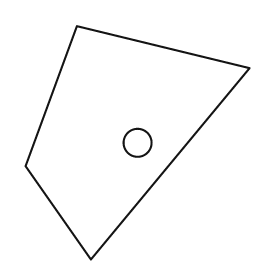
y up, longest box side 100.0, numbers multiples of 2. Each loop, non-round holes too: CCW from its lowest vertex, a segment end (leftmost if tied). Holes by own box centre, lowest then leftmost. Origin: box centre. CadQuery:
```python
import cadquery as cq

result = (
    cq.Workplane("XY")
    .moveTo(-20.0, -50.0)
    .lineTo(48.0, 32.0)
    .lineTo(-26.0, 50.0)
    .lineTo(-48.0, -10.0)
    .close()
    .moveTo(0.0, 0.0)
    .circle(6.0)
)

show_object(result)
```